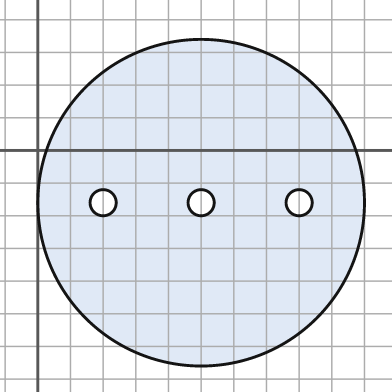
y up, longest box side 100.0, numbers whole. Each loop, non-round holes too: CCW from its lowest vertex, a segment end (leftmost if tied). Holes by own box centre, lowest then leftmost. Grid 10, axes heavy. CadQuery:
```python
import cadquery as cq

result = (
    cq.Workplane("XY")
    .moveTo(50.0, -16.0)
    .circle(50.0)
    .moveTo(20.0, -16.0)
    .circle(4.0)
    .moveTo(50.0, -16.0)
    .circle(4.0)
    .moveTo(80.0, -16.0)
    .circle(4.0)
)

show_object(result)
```